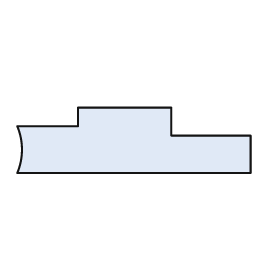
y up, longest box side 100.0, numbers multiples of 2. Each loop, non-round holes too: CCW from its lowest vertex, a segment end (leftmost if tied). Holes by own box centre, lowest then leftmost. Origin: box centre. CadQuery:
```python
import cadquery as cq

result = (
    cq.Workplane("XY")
    .moveTo(-50.0, -14.0)
    .lineTo(50.0, -14.0)
    .lineTo(50.0, 2.0)
    .lineTo(16.0, 2.0)
    .lineTo(16.0, 14.0)
    .lineTo(-24.0, 14.0)
    .lineTo(-24.0, 6.0)
    .lineTo(-50.0, 6.0)
    .threePointArc((-48.0, -4.0), (-50.0, -14.0))
    .close()
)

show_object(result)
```